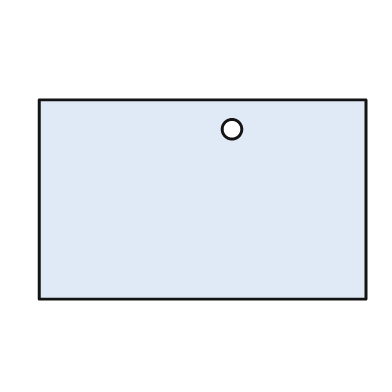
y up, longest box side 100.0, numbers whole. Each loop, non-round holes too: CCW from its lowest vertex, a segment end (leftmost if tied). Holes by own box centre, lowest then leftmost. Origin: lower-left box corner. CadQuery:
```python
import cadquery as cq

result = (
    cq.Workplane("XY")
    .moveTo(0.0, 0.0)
    .lineTo(100.0, 0.0)
    .lineTo(100.0, 61.0)
    .lineTo(0.0, 61.0)
    .close()
    .moveTo(59.0, 52.0)
    .circle(3.0)
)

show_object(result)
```